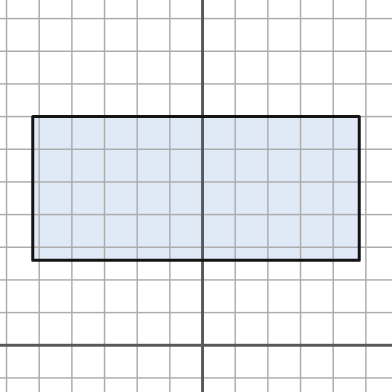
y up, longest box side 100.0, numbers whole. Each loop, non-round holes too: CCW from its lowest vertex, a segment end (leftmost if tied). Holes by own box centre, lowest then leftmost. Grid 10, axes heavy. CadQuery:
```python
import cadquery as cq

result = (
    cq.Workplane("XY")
    .moveTo(-52.0, 26.0)
    .lineTo(48.0, 26.0)
    .lineTo(48.0, 70.0)
    .lineTo(-52.0, 70.0)
    .close()
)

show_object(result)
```